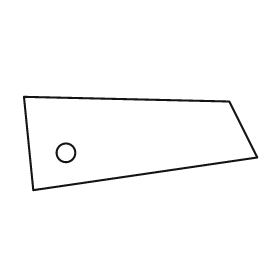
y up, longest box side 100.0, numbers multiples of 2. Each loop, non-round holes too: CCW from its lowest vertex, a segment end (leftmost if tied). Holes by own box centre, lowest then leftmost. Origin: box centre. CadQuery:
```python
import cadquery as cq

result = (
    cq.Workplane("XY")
    .moveTo(-46.0, -20.0)
    .lineTo(50.0, -6.0)
    .lineTo(38.0, 18.0)
    .lineTo(-50.0, 20.0)
    .close()
    .moveTo(-32.0, -4.0)
    .circle(4.0)
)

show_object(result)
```